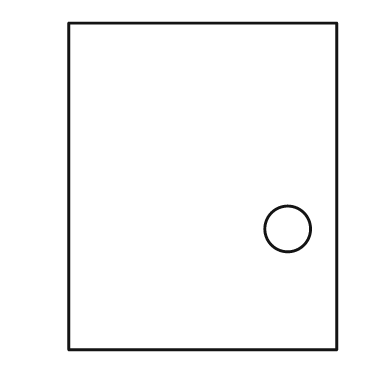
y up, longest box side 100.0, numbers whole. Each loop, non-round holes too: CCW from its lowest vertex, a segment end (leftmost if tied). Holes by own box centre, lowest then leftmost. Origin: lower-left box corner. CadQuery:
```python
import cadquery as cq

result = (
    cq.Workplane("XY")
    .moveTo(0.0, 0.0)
    .lineTo(82.0, 0.0)
    .lineTo(82.0, 100.0)
    .lineTo(0.0, 100.0)
    .close()
    .moveTo(67.0, 37.0)
    .circle(7.0)
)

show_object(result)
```